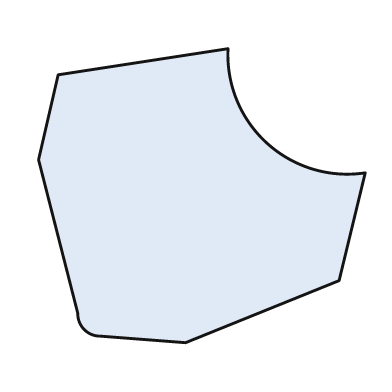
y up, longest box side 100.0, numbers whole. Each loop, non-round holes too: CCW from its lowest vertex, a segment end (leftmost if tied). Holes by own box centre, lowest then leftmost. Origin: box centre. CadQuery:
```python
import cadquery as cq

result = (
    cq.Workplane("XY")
    .moveTo(-5.0, -45.0)
    .lineTo(42.0, -26.0)
    .lineTo(50.0, 7.0)
    .threePointArc((20.0, 16.0), (8.0, 45.0))
    .lineTo(-44.0, 37.0)
    .lineTo(-50.0, 11.0)
    .lineTo(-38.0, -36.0)
    .threePointArc((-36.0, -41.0), (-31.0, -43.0))
    .close()
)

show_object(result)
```